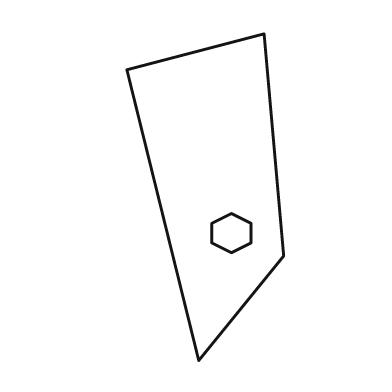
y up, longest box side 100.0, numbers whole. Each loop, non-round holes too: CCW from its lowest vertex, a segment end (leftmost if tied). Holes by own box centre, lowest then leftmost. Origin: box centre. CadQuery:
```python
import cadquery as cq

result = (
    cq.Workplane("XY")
    .moveTo(-2.0, -50.0)
    .lineTo(24.0, -18.0)
    .lineTo(18.0, 50.0)
    .lineTo(-24.0, 39.0)
    .close()
    .moveTo(8.0, -17.0)
    .lineTo(14.0, -14.0)
    .lineTo(14.0, -8.0)
    .lineTo(8.0, -5.0)
    .lineTo(2.0, -8.0)
    .lineTo(2.0, -14.0)
    .close()
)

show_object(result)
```